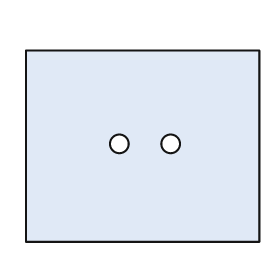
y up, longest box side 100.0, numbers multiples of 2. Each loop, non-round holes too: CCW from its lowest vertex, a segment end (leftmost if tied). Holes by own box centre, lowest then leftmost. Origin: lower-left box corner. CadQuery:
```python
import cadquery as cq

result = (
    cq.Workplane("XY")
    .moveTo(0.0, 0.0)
    .lineTo(100.0, 0.0)
    .lineTo(100.0, 82.0)
    .lineTo(0.0, 82.0)
    .close()
    .moveTo(40.0, 42.0)
    .circle(4.0)
    .moveTo(62.0, 42.0)
    .circle(4.0)
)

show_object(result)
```